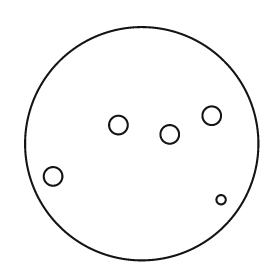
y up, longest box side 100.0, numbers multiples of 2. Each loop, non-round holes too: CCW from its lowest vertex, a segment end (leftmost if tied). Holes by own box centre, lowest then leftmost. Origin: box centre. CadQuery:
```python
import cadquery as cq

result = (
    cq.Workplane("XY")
    .moveTo(0.0, 0.0)
    .circle(50.0)
    .moveTo(34.0, -24.0)
    .circle(2.0)
    .moveTo(-38.0, -14.0)
    .circle(4.0)
    .moveTo(12.0, 4.0)
    .circle(4.0)
    .moveTo(-10.0, 8.0)
    .circle(4.0)
    .moveTo(30.0, 12.0)
    .circle(4.0)
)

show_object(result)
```